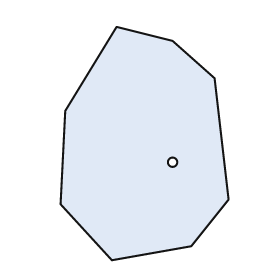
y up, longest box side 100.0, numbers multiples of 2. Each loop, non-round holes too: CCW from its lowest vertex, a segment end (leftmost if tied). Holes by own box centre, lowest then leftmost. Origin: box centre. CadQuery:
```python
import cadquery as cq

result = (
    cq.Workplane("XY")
    .moveTo(-14.0, -50.0)
    .lineTo(20.0, -44.0)
    .lineTo(36.0, -24.0)
    .lineTo(30.0, 28.0)
    .lineTo(12.0, 44.0)
    .lineTo(-12.0, 50.0)
    .lineTo(-34.0, 14.0)
    .lineTo(-36.0, -26.0)
    .close()
    .moveTo(12.0, -8.0)
    .circle(2.0)
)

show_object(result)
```